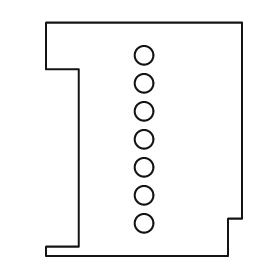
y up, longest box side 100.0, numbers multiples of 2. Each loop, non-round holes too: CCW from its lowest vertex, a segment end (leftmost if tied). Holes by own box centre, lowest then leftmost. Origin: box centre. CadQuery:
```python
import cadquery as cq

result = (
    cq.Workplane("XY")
    .moveTo(-42.0, -50.0)
    .lineTo(36.0, -50.0)
    .lineTo(36.0, -34.0)
    .lineTo(42.0, -34.0)
    .lineTo(42.0, 50.0)
    .lineTo(-42.0, 50.0)
    .lineTo(-42.0, 30.0)
    .lineTo(-28.0, 30.0)
    .lineTo(-28.0, -46.0)
    .lineTo(-42.0, -46.0)
    .close()
    .moveTo(0.0, -36.0)
    .circle(4.0)
    .moveTo(0.0, -24.0)
    .circle(4.0)
    .moveTo(0.0, -12.0)
    .circle(4.0)
    .moveTo(0.0, 0.0)
    .circle(4.0)
    .moveTo(0.0, 12.0)
    .circle(4.0)
    .moveTo(0.0, 24.0)
    .circle(4.0)
    .moveTo(0.0, 36.0)
    .circle(4.0)
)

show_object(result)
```